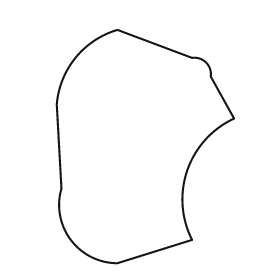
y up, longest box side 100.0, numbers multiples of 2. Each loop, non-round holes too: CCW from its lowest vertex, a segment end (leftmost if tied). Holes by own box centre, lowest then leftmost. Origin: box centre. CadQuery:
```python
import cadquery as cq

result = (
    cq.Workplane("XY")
    .moveTo(-12.0, -50.0)
    .lineTo(20.0, -40.0)
    .threePointArc((18.0, -10.0), (38.0, 12.0))
    .lineTo(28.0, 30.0)
    .threePointArc((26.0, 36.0), (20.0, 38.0))
    .lineTo(-12.0, 50.0)
    .threePointArc((-30.0, 38.0), (-38.0, 18.0))
    .lineTo(-36.0, -18.0)
    .threePointArc((-32.0, -40.0), (-12.0, -50.0))
    .close()
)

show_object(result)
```